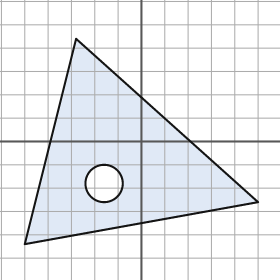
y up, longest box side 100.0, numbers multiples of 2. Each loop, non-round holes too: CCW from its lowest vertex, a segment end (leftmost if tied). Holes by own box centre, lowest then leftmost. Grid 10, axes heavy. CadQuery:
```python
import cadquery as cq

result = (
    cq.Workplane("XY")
    .moveTo(-50.0, -44.0)
    .lineTo(50.0, -26.0)
    .lineTo(-28.0, 44.0)
    .close()
    .moveTo(-16.0, -18.0)
    .circle(8.0)
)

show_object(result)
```